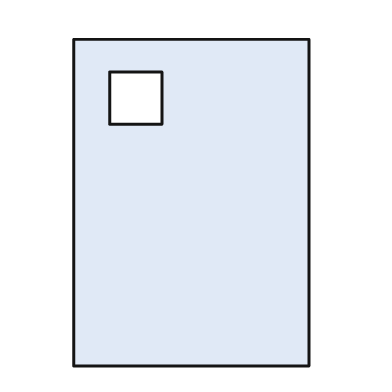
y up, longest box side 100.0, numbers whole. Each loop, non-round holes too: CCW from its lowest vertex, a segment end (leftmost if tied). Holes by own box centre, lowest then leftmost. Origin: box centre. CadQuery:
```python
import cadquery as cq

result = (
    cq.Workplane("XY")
    .moveTo(-36.0, -50.0)
    .lineTo(36.0, -50.0)
    .lineTo(36.0, 50.0)
    .lineTo(-36.0, 50.0)
    .close()
    .moveTo(-25.0, 24.0)
    .lineTo(-9.0, 24.0)
    .lineTo(-9.0, 40.0)
    .lineTo(-25.0, 40.0)
    .close()
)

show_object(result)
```